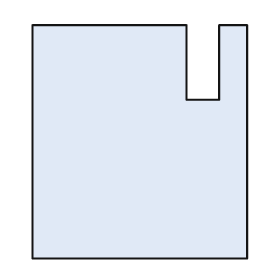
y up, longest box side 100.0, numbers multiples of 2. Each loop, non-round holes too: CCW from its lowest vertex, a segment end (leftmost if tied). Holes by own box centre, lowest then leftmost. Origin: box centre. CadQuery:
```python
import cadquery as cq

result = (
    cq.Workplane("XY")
    .moveTo(-46.0, -50.0)
    .lineTo(46.0, -50.0)
    .lineTo(46.0, 50.0)
    .lineTo(34.0, 50.0)
    .lineTo(34.0, 18.0)
    .lineTo(20.0, 18.0)
    .lineTo(20.0, 50.0)
    .lineTo(-46.0, 50.0)
    .close()
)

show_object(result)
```